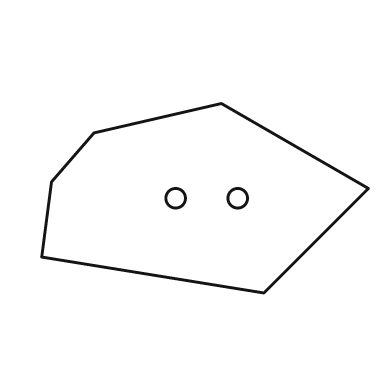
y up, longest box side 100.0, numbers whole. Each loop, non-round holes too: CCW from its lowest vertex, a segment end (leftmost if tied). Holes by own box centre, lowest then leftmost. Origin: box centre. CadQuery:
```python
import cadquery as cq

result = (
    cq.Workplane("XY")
    .moveTo(18.0, -29.0)
    .lineTo(50.0, 3.0)
    .lineTo(5.0, 29.0)
    .lineTo(-34.0, 20.0)
    .lineTo(-47.0, 5.0)
    .lineTo(-50.0, -18.0)
    .close()
    .moveTo(-9.0, 0.0)
    .circle(3.0)
    .moveTo(10.0, 0.0)
    .circle(3.0)
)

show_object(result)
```